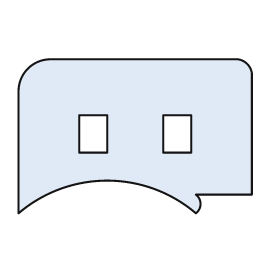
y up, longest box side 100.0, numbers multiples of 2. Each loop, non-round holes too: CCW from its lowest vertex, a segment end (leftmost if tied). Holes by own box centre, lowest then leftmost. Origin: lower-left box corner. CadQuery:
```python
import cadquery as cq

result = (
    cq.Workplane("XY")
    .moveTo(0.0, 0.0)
    .threePointArc((38.0, 14.0), (76.0, 0.0))
    .threePointArc((78.0, 4.0), (76.0, 8.0))
    .lineTo(100.0, 8.0)
    .lineTo(100.0, 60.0)
    .threePointArc((98.0, 64.0), (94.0, 66.0))
    .lineTo(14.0, 66.0)
    .threePointArc((4.0, 62.0), (0.0, 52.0))
    .close()
    .moveTo(26.0, 26.0)
    .lineTo(38.0, 26.0)
    .lineTo(38.0, 42.0)
    .lineTo(26.0, 42.0)
    .close()
    .moveTo(62.0, 26.0)
    .lineTo(74.0, 26.0)
    .lineTo(74.0, 42.0)
    .lineTo(62.0, 42.0)
    .close()
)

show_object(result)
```